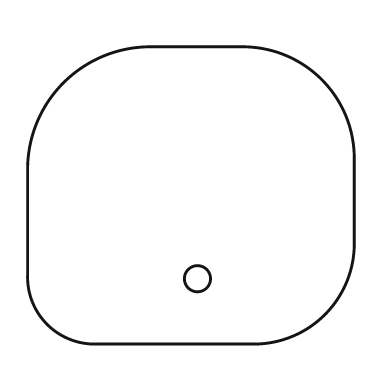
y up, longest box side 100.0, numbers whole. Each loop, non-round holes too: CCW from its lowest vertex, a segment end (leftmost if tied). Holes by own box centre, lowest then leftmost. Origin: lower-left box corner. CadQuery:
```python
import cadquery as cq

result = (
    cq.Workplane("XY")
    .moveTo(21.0, 0.0)
    .lineTo(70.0, 0.0)
    .threePointArc((91.0, 9.0), (100.0, 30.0))
    .lineTo(100.0, 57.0)
    .threePointArc((90.0, 81.0), (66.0, 91.0))
    .lineTo(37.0, 91.0)
    .threePointArc((11.0, 80.0), (0.0, 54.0))
    .lineTo(0.0, 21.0)
    .threePointArc((6.0, 6.0), (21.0, 0.0))
    .close()
    .moveTo(52.0, 20.0)
    .circle(4.0)
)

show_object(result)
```